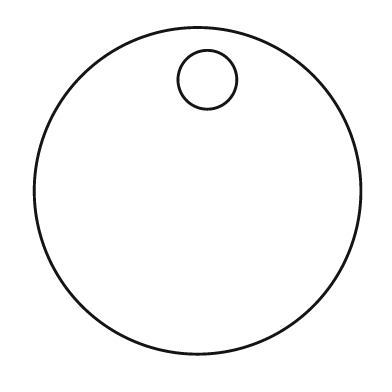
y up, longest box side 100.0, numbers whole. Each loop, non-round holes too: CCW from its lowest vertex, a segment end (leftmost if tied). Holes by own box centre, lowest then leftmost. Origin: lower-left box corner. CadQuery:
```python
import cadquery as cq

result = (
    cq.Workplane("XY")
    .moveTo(50.0, 50.0)
    .circle(50.0)
    .moveTo(53.0, 84.0)
    .circle(9.0)
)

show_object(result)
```